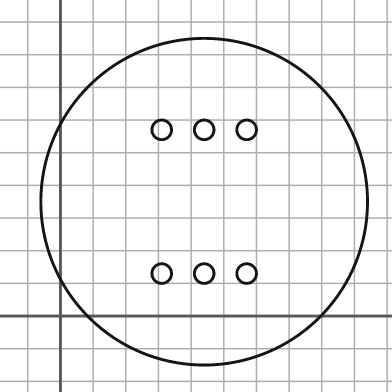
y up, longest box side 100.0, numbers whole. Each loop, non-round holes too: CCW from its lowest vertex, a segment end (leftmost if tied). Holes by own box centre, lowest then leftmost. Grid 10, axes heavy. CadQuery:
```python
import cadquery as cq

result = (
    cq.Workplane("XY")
    .moveTo(44.0, 35.0)
    .circle(50.0)
    .moveTo(31.0, 13.0)
    .circle(3.0)
    .moveTo(44.0, 13.0)
    .circle(3.0)
    .moveTo(57.0, 13.0)
    .circle(3.0)
    .moveTo(31.0, 57.0)
    .circle(3.0)
    .moveTo(44.0, 57.0)
    .circle(3.0)
    .moveTo(57.0, 57.0)
    .circle(3.0)
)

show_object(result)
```